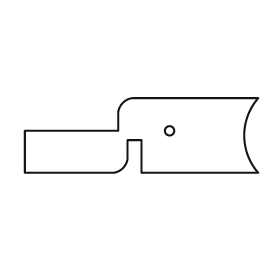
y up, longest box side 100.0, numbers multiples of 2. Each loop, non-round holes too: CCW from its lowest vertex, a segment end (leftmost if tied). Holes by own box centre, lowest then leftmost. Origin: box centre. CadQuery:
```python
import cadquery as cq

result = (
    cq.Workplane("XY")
    .moveTo(-50.0, -16.0)
    .lineTo(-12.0, -16.0)
    .threePointArc((-8.0, -14.0), (-6.0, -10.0))
    .lineTo(-6.0, -2.0)
    .lineTo(0.0, -2.0)
    .lineTo(0.0, -16.0)
    .lineTo(50.0, -16.0)
    .threePointArc((44.0, 0.0), (50.0, 16.0))
    .lineTo(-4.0, 16.0)
    .threePointArc((-8.0, 14.0), (-10.0, 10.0))
    .lineTo(-10.0, 2.0)
    .lineTo(-50.0, 2.0)
    .close()
    .moveTo(12.0, 2.0)
    .circle(2.0)
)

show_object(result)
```